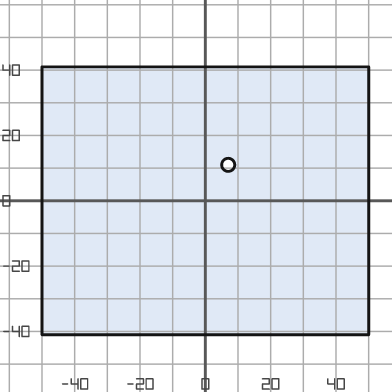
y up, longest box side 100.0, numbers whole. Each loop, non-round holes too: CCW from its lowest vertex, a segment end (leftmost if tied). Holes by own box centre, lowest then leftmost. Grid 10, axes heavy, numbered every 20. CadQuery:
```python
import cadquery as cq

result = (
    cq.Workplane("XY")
    .moveTo(-50.0, -41.0)
    .lineTo(50.0, -41.0)
    .lineTo(50.0, 41.0)
    .lineTo(-50.0, 41.0)
    .close()
    .moveTo(7.0, 11.0)
    .circle(2.0)
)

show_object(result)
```